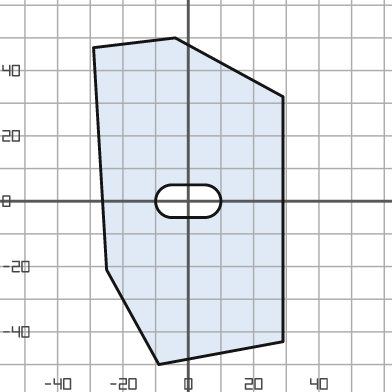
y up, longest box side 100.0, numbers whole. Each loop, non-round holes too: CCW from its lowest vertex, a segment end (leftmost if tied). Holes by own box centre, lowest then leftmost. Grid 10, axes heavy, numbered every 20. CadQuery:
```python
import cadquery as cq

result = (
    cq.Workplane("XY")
    .moveTo(-9.0, -50.0)
    .lineTo(29.0, -43.0)
    .lineTo(29.0, 32.0)
    .lineTo(-4.0, 50.0)
    .lineTo(-29.0, 47.0)
    .lineTo(-25.0, -21.0)
    .close()
    .moveTo(-5.0, -5.0)
    .lineTo(5.0, -5.0)
    .threePointArc((10.0, 0.0), (5.0, 5.0))
    .lineTo(-5.0, 5.0)
    .threePointArc((-10.0, 0.0), (-5.0, -5.0))
    .close()
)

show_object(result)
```